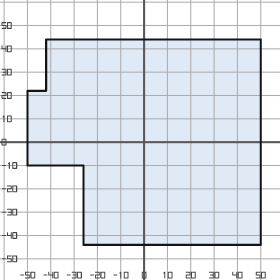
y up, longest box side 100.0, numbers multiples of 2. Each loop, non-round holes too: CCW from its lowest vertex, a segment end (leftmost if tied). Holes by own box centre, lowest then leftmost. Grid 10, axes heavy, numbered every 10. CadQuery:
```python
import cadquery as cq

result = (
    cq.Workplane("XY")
    .moveTo(-26.0, -44.0)
    .lineTo(50.0, -44.0)
    .lineTo(50.0, 44.0)
    .lineTo(-42.0, 44.0)
    .lineTo(-42.0, 22.0)
    .lineTo(-50.0, 22.0)
    .lineTo(-50.0, -10.0)
    .lineTo(-26.0, -10.0)
    .close()
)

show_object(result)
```